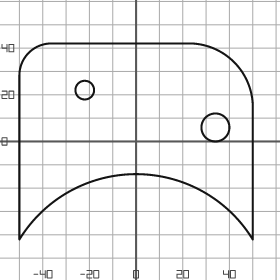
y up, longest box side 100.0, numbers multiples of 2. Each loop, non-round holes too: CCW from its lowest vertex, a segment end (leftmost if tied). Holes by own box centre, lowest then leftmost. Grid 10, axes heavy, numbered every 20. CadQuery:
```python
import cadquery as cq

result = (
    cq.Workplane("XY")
    .moveTo(-50.0, -42.0)
    .threePointArc((0.0, -14.0), (50.0, -42.0))
    .lineTo(50.0, 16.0)
    .threePointArc((42.0, 34.0), (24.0, 42.0))
    .lineTo(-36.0, 42.0)
    .threePointArc((-46.0, 38.0), (-50.0, 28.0))
    .close()
    .moveTo(34.0, 6.0)
    .circle(6.0)
    .moveTo(-22.0, 22.0)
    .circle(4.0)
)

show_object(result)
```